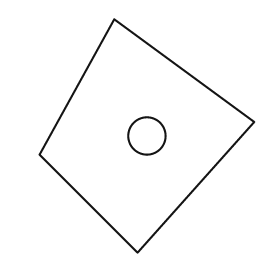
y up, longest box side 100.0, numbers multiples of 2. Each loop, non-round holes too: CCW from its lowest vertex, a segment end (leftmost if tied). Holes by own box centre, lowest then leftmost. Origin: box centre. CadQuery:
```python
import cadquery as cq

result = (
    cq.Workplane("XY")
    .moveTo(-4.0, -50.0)
    .lineTo(46.0, 6.0)
    .lineTo(-14.0, 50.0)
    .lineTo(-46.0, -8.0)
    .close()
    .moveTo(0.0, 0.0)
    .circle(8.0)
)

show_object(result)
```